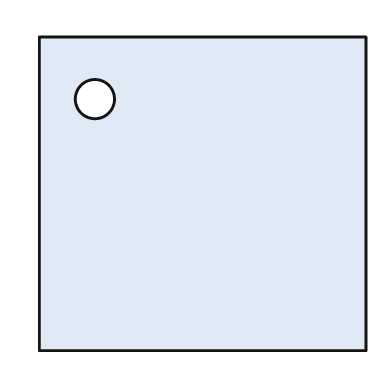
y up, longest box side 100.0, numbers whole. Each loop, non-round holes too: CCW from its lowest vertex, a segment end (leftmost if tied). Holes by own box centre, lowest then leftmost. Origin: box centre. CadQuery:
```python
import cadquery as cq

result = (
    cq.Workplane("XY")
    .moveTo(-50.0, -48.0)
    .lineTo(50.0, -48.0)
    .lineTo(50.0, 48.0)
    .lineTo(-50.0, 48.0)
    .close()
    .moveTo(-33.0, 29.0)
    .circle(6.0)
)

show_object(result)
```